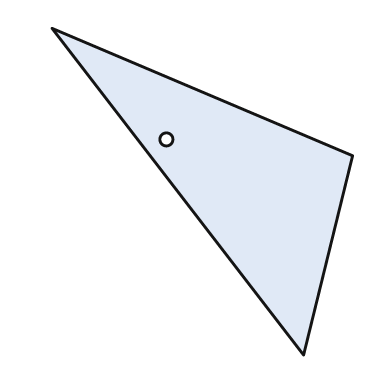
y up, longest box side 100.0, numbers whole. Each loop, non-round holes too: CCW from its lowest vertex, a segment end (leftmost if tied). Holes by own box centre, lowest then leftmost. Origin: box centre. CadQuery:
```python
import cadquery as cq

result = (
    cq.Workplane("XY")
    .moveTo(31.0, -50.0)
    .lineTo(46.0, 11.0)
    .lineTo(-46.0, 50.0)
    .close()
    .moveTo(-11.0, 16.0)
    .circle(2.0)
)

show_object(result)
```